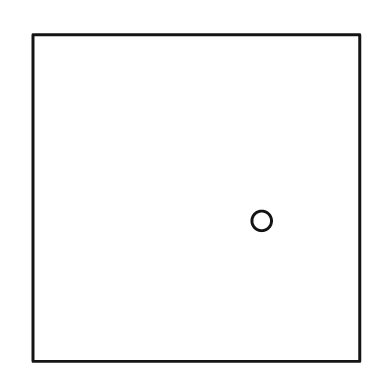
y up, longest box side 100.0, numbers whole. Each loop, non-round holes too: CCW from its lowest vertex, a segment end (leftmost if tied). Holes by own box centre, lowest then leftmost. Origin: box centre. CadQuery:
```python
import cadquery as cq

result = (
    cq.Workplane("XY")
    .moveTo(-50.0, -50.0)
    .lineTo(50.0, -50.0)
    .lineTo(50.0, 50.0)
    .lineTo(-50.0, 50.0)
    .close()
    .moveTo(20.0, -7.0)
    .circle(3.0)
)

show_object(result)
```